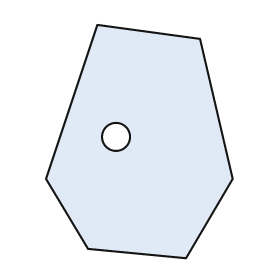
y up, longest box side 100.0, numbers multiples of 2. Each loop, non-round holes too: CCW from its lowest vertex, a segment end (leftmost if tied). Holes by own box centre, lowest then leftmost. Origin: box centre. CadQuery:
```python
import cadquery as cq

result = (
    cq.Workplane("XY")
    .moveTo(20.0, -50.0)
    .lineTo(40.0, -16.0)
    .lineTo(26.0, 44.0)
    .lineTo(-18.0, 50.0)
    .lineTo(-40.0, -16.0)
    .lineTo(-22.0, -46.0)
    .close()
    .moveTo(-10.0, 2.0)
    .circle(6.0)
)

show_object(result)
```